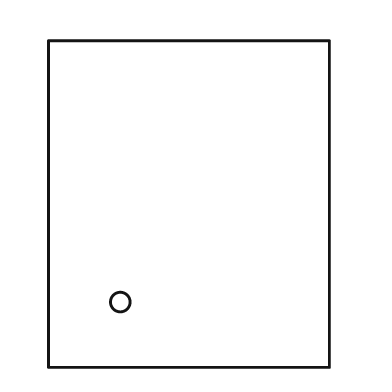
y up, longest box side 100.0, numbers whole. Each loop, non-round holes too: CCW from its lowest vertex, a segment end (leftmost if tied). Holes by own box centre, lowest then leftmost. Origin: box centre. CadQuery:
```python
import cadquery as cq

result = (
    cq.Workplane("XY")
    .moveTo(-43.0, -50.0)
    .lineTo(43.0, -50.0)
    .lineTo(43.0, 50.0)
    .lineTo(-43.0, 50.0)
    .close()
    .moveTo(-21.0, -30.0)
    .circle(3.0)
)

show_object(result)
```